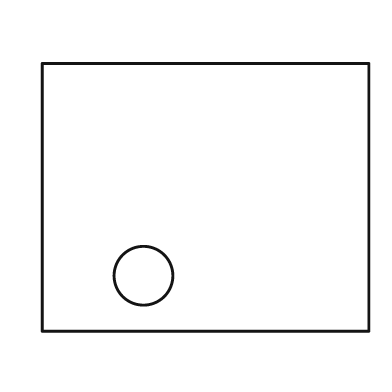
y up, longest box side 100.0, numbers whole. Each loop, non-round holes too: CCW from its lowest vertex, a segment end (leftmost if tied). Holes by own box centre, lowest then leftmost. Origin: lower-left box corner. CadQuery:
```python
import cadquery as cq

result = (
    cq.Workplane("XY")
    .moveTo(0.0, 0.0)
    .lineTo(100.0, 0.0)
    .lineTo(100.0, 82.0)
    .lineTo(0.0, 82.0)
    .close()
    .moveTo(31.0, 17.0)
    .circle(9.0)
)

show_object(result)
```